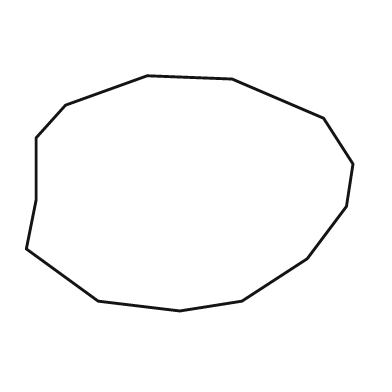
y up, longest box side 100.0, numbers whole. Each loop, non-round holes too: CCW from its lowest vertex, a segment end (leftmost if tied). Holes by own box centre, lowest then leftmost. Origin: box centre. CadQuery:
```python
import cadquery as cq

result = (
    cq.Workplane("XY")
    .moveTo(-3.0, -36.0)
    .lineTo(16.0, -33.0)
    .lineTo(36.0, -20.0)
    .lineTo(48.0, -4.0)
    .lineTo(50.0, 9.0)
    .lineTo(41.0, 23.0)
    .lineTo(13.0, 35.0)
    .lineTo(-13.0, 36.0)
    .lineTo(-38.0, 27.0)
    .lineTo(-47.0, 17.0)
    .lineTo(-47.0, -2.0)
    .lineTo(-50.0, -17.0)
    .lineTo(-28.0, -33.0)
    .close()
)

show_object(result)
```